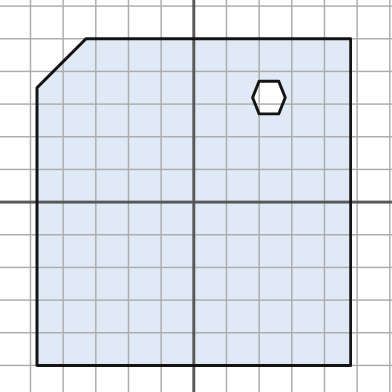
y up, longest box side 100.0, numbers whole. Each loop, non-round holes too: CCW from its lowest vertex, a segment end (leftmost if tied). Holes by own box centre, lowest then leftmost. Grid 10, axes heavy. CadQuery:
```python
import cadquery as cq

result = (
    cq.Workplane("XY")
    .moveTo(-48.0, -50.0)
    .lineTo(48.0, -50.0)
    .lineTo(48.0, 50.0)
    .lineTo(-33.0, 50.0)
    .lineTo(-48.0, 35.0)
    .close()
    .moveTo(20.0, 27.0)
    .lineTo(26.0, 27.0)
    .lineTo(28.0, 32.0)
    .lineTo(26.0, 37.0)
    .lineTo(20.0, 37.0)
    .lineTo(18.0, 32.0)
    .close()
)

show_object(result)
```